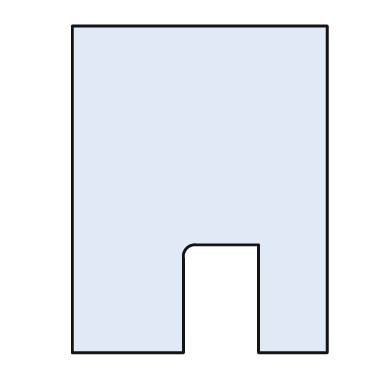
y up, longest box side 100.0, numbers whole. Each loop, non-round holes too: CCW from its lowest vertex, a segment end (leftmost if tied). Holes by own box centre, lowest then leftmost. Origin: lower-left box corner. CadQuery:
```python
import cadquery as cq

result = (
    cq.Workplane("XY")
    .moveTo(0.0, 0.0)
    .lineTo(34.0, 0.0)
    .lineTo(34.0, 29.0)
    .threePointArc((35.0, 32.0), (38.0, 33.0))
    .lineTo(57.0, 33.0)
    .lineTo(57.0, 0.0)
    .lineTo(78.0, 0.0)
    .lineTo(78.0, 100.0)
    .lineTo(0.0, 100.0)
    .close()
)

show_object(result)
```